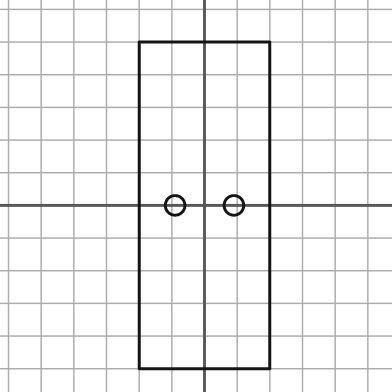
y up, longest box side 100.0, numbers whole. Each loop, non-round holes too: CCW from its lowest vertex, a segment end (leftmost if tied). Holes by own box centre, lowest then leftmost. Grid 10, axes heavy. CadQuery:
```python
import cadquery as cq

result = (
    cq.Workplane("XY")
    .moveTo(-20.0, -50.0)
    .lineTo(20.0, -50.0)
    .lineTo(20.0, 50.0)
    .lineTo(-20.0, 50.0)
    .close()
    .moveTo(-9.0, 0.0)
    .circle(3.0)
    .moveTo(9.0, 0.0)
    .circle(3.0)
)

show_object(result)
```